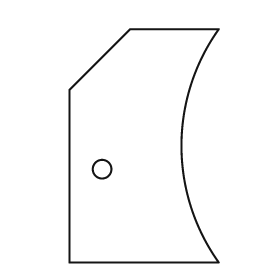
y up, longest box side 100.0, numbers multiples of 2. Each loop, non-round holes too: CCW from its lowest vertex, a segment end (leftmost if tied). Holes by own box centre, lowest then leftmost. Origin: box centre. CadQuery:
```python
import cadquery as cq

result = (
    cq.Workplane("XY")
    .moveTo(-32.0, -50.0)
    .lineTo(32.0, -50.0)
    .threePointArc((16.0, 0.0), (32.0, 50.0))
    .lineTo(-6.0, 50.0)
    .lineTo(-32.0, 24.0)
    .close()
    .moveTo(-18.0, -10.0)
    .circle(4.0)
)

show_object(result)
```